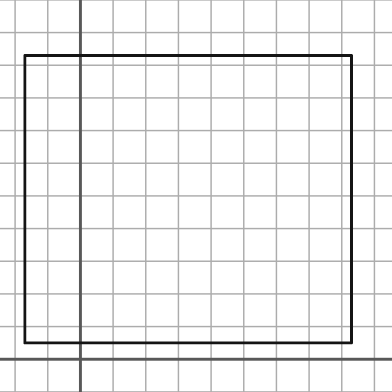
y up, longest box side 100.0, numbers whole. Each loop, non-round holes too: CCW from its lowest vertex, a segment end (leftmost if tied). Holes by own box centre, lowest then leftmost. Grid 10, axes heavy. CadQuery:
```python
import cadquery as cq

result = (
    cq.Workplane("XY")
    .moveTo(-17.0, 5.0)
    .lineTo(83.0, 5.0)
    .lineTo(83.0, 93.0)
    .lineTo(-17.0, 93.0)
    .close()
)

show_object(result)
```